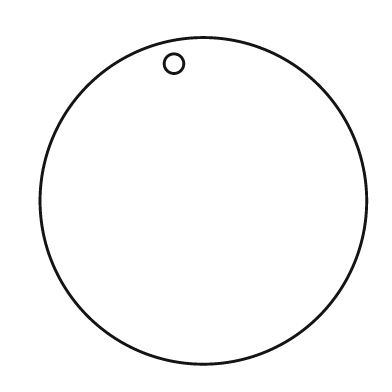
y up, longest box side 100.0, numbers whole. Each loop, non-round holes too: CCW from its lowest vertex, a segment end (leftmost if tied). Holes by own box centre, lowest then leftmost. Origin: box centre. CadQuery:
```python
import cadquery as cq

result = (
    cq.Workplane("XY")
    .moveTo(0.0, 0.0)
    .circle(50.0)
    .moveTo(-9.0, 42.0)
    .circle(3.0)
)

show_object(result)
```